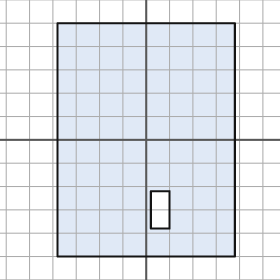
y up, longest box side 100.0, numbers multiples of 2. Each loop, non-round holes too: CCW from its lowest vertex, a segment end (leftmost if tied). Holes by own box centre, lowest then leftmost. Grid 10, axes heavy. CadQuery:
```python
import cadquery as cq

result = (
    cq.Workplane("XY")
    .moveTo(-38.0, -50.0)
    .lineTo(38.0, -50.0)
    .lineTo(38.0, 50.0)
    .lineTo(-38.0, 50.0)
    .close()
    .moveTo(2.0, -38.0)
    .lineTo(10.0, -38.0)
    .lineTo(10.0, -22.0)
    .lineTo(2.0, -22.0)
    .close()
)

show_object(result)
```